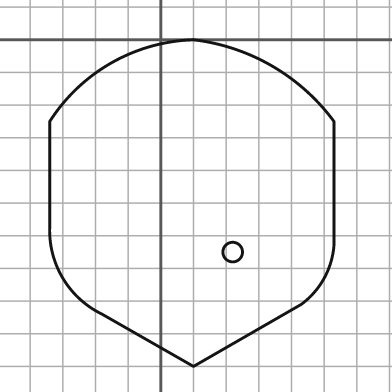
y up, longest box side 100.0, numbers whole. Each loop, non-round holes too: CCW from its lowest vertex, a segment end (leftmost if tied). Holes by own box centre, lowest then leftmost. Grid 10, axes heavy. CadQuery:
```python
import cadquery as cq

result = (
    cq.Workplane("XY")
    .moveTo(10.0, -100.0)
    .lineTo(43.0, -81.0)
    .threePointArc((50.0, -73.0), (53.0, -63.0))
    .lineTo(53.0, -25.0)
    .threePointArc((34.0, -8.0), (10.0, 0.0))
    .threePointArc((-15.0, -7.0), (-34.0, -25.0))
    .lineTo(-34.0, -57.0)
    .threePointArc((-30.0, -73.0), (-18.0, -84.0))
    .close()
    .moveTo(22.0, -65.0)
    .circle(3.0)
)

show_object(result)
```